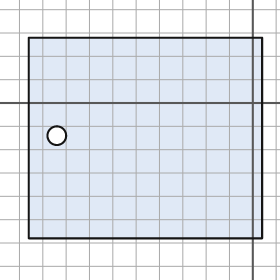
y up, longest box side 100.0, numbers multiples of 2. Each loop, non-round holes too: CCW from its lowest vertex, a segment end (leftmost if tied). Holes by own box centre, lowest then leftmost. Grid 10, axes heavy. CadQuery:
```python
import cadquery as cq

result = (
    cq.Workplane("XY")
    .moveTo(-96.0, -58.0)
    .lineTo(4.0, -58.0)
    .lineTo(4.0, 28.0)
    .lineTo(-96.0, 28.0)
    .close()
    .moveTo(-84.0, -14.0)
    .circle(4.0)
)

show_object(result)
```